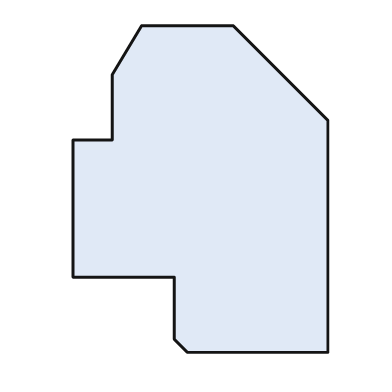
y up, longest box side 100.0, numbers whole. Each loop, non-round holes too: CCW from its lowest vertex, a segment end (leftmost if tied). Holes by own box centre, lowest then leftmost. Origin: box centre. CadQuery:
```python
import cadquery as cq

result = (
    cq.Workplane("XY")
    .moveTo(-4.0, -50.0)
    .lineTo(39.0, -50.0)
    .lineTo(39.0, 21.0)
    .lineTo(10.0, 50.0)
    .lineTo(-18.0, 50.0)
    .lineTo(-27.0, 35.0)
    .lineTo(-27.0, 15.0)
    .lineTo(-39.0, 15.0)
    .lineTo(-39.0, -27.0)
    .lineTo(-8.0, -27.0)
    .lineTo(-8.0, -46.0)
    .close()
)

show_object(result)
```